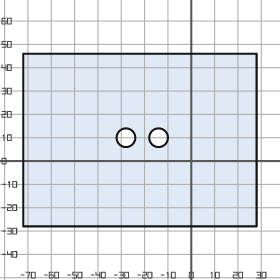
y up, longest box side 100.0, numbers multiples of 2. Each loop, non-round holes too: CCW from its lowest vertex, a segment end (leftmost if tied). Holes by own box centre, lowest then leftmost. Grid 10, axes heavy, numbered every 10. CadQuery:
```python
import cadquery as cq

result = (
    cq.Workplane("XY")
    .moveTo(-72.0, -28.0)
    .lineTo(28.0, -28.0)
    .lineTo(28.0, 46.0)
    .lineTo(-72.0, 46.0)
    .close()
    .moveTo(-28.0, 10.0)
    .circle(4.0)
    .moveTo(-14.0, 10.0)
    .circle(4.0)
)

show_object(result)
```